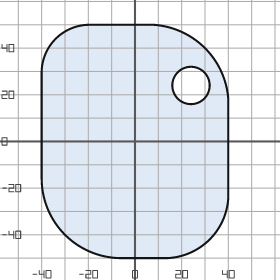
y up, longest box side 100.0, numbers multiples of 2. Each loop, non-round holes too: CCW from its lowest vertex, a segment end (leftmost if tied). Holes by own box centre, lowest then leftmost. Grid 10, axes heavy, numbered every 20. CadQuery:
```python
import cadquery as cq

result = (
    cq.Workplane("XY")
    .moveTo(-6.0, -50.0)
    .lineTo(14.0, -50.0)
    .threePointArc((32.0, -42.0), (40.0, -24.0))
    .lineTo(40.0, 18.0)
    .threePointArc((30.0, 40.0), (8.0, 50.0))
    .lineTo(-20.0, 50.0)
    .threePointArc((-34.0, 44.0), (-40.0, 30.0))
    .lineTo(-40.0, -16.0)
    .threePointArc((-30.0, -40.0), (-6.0, -50.0))
    .close()
    .moveTo(24.0, 24.0)
    .circle(8.0)
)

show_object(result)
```